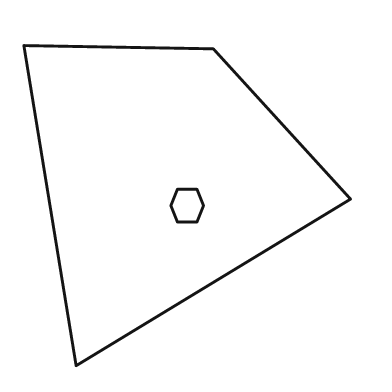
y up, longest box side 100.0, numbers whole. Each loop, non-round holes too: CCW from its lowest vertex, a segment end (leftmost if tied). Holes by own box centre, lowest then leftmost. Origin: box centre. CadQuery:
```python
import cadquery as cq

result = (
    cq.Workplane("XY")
    .moveTo(-34.0, -49.0)
    .lineTo(50.0, 2.0)
    .lineTo(8.0, 48.0)
    .lineTo(-50.0, 49.0)
    .close()
    .moveTo(-3.0, -5.0)
    .lineTo(3.0, -5.0)
    .lineTo(5.0, 0.0)
    .lineTo(3.0, 5.0)
    .lineTo(-3.0, 5.0)
    .lineTo(-5.0, 0.0)
    .close()
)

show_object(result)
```